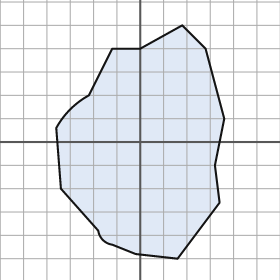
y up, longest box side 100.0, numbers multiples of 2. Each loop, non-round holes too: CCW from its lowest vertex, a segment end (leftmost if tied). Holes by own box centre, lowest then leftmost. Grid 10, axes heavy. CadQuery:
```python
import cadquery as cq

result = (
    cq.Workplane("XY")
    .moveTo(16.0, -50.0)
    .lineTo(34.0, -26.0)
    .lineTo(32.0, -10.0)
    .lineTo(36.0, 10.0)
    .lineTo(28.0, 40.0)
    .lineTo(18.0, 50.0)
    .lineTo(0.0, 40.0)
    .lineTo(-12.0, 40.0)
    .lineTo(-22.0, 20.0)
    .threePointArc((-30.0, 14.0), (-36.0, 6.0))
    .lineTo(-34.0, -20.0)
    .lineTo(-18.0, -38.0)
    .threePointArc((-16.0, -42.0), (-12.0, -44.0))
    .lineTo(-2.0, -48.0)
    .close()
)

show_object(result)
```